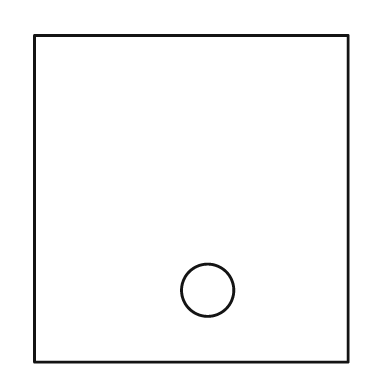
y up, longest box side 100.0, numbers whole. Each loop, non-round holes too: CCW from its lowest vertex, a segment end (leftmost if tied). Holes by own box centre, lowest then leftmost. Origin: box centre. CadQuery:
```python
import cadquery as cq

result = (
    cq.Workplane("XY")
    .moveTo(-48.0, -50.0)
    .lineTo(48.0, -50.0)
    .lineTo(48.0, 50.0)
    .lineTo(-48.0, 50.0)
    .close()
    .moveTo(5.0, -28.0)
    .circle(8.0)
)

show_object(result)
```